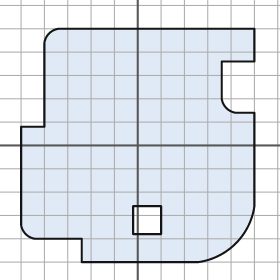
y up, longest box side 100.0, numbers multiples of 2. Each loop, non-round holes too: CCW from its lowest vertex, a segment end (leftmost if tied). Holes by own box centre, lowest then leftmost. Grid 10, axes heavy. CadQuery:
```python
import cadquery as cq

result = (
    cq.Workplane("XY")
    .moveTo(-24.0, -50.0)
    .lineTo(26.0, -50.0)
    .threePointArc((42.0, -42.0), (50.0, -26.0))
    .lineTo(50.0, 14.0)
    .lineTo(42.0, 14.0)
    .threePointArc((38.0, 16.0), (36.0, 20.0))
    .lineTo(36.0, 36.0)
    .lineTo(50.0, 36.0)
    .lineTo(50.0, 50.0)
    .lineTo(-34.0, 50.0)
    .threePointArc((-38.0, 48.0), (-40.0, 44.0))
    .lineTo(-40.0, 8.0)
    .lineTo(-50.0, 8.0)
    .lineTo(-50.0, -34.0)
    .threePointArc((-48.0, -38.0), (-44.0, -40.0))
    .lineTo(-24.0, -40.0)
    .close()
    .moveTo(-2.0, -38.0)
    .lineTo(10.0, -38.0)
    .lineTo(10.0, -26.0)
    .lineTo(-2.0, -26.0)
    .close()
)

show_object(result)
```